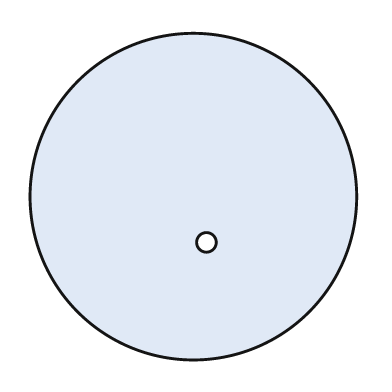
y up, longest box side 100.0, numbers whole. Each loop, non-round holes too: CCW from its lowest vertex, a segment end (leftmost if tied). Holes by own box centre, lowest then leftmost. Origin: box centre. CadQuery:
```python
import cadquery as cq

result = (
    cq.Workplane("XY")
    .moveTo(0.0, 0.0)
    .circle(50.0)
    .moveTo(4.0, -14.0)
    .circle(3.0)
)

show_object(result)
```